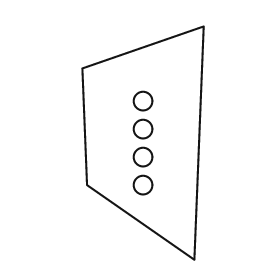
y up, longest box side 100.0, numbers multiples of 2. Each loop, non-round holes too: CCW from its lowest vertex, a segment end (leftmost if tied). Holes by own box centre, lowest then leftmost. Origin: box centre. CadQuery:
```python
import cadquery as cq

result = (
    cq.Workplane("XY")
    .moveTo(22.0, -50.0)
    .lineTo(26.0, 50.0)
    .lineTo(-26.0, 32.0)
    .lineTo(-24.0, -18.0)
    .close()
    .moveTo(0.0, -18.0)
    .circle(4.0)
    .moveTo(0.0, -6.0)
    .circle(4.0)
    .moveTo(0.0, 6.0)
    .circle(4.0)
    .moveTo(0.0, 18.0)
    .circle(4.0)
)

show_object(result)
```